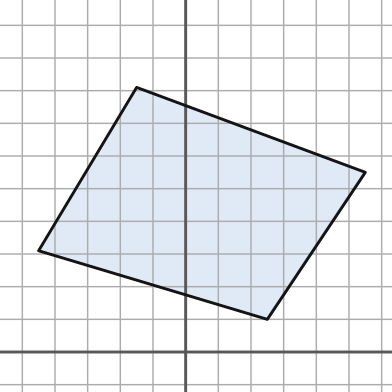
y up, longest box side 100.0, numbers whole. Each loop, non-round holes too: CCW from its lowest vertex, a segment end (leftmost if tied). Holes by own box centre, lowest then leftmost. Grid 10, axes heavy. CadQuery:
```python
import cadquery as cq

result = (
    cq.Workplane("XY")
    .moveTo(25.0, 10.0)
    .lineTo(55.0, 55.0)
    .lineTo(-15.0, 81.0)
    .lineTo(-45.0, 31.0)
    .close()
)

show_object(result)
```